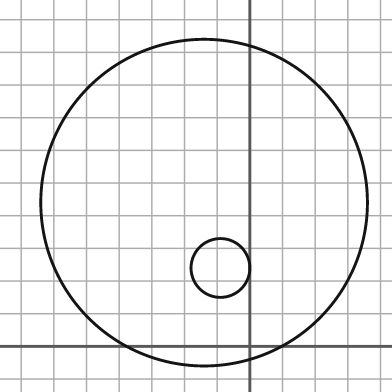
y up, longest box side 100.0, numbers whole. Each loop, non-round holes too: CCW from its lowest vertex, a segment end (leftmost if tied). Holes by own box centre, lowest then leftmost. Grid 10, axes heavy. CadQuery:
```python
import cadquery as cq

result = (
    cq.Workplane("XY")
    .moveTo(-14.0, 44.0)
    .circle(50.0)
    .moveTo(-9.0, 24.0)
    .circle(9.0)
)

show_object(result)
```